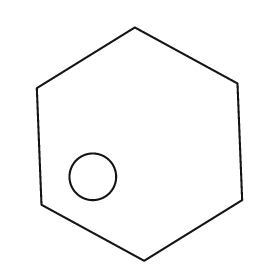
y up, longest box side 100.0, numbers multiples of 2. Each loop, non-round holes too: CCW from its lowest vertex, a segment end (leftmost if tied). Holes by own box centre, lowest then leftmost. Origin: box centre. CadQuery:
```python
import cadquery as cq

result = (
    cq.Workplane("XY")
    .moveTo(2.0, -50.0)
    .lineTo(44.0, -24.0)
    .lineTo(42.0, 26.0)
    .lineTo(-2.0, 50.0)
    .lineTo(-44.0, 24.0)
    .lineTo(-42.0, -26.0)
    .close()
    .moveTo(-20.0, -14.0)
    .circle(10.0)
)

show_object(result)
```